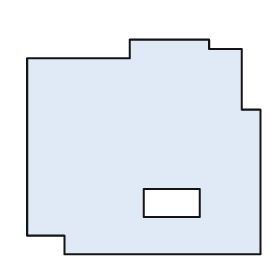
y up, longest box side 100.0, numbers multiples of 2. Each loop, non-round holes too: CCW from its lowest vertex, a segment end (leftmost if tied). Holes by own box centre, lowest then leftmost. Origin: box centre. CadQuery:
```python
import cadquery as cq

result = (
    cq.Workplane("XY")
    .moveTo(-34.0, -46.0)
    .lineTo(50.0, -46.0)
    .lineTo(50.0, 16.0)
    .lineTo(42.0, 16.0)
    .lineTo(42.0, 42.0)
    .lineTo(28.0, 42.0)
    .lineTo(28.0, 46.0)
    .lineTo(-6.0, 46.0)
    .lineTo(-6.0, 38.0)
    .lineTo(-50.0, 38.0)
    .lineTo(-50.0, -38.0)
    .lineTo(-34.0, -38.0)
    .close()
    .moveTo(0.0, -30.0)
    .lineTo(24.0, -30.0)
    .lineTo(24.0, -18.0)
    .lineTo(0.0, -18.0)
    .close()
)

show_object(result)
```